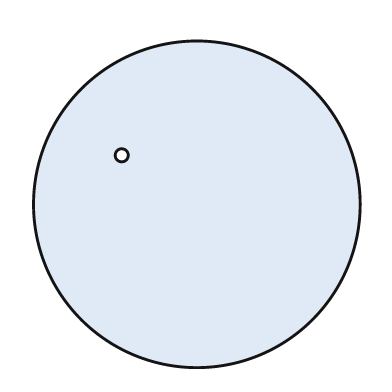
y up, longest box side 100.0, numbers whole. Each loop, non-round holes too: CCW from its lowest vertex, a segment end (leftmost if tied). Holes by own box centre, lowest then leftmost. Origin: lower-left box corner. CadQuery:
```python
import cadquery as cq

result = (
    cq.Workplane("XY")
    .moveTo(50.0, 50.0)
    .circle(50.0)
    .moveTo(27.0, 65.0)
    .circle(2.0)
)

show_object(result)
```